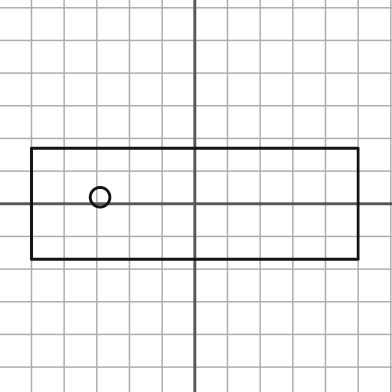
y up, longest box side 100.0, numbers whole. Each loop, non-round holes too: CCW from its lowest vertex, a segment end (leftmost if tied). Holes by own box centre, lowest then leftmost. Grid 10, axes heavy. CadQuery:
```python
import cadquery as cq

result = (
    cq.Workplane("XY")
    .moveTo(-50.0, -17.0)
    .lineTo(50.0, -17.0)
    .lineTo(50.0, 17.0)
    .lineTo(-50.0, 17.0)
    .close()
    .moveTo(-29.0, 2.0)
    .circle(3.0)
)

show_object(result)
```